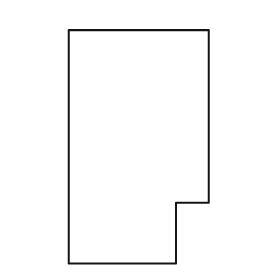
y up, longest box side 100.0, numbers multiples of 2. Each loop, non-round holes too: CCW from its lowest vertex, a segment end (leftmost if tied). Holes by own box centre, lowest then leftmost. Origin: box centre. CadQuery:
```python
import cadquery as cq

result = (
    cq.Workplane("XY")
    .moveTo(-30.0, -50.0)
    .lineTo(16.0, -50.0)
    .lineTo(16.0, -24.0)
    .lineTo(30.0, -24.0)
    .lineTo(30.0, 50.0)
    .lineTo(-30.0, 50.0)
    .close()
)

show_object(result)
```